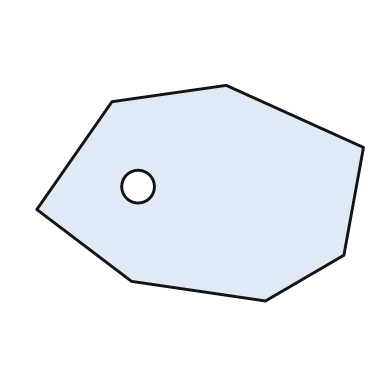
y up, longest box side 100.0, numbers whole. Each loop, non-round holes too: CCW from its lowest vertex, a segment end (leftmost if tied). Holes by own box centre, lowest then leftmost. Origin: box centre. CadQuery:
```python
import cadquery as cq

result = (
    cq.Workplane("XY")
    .moveTo(20.0, -33.0)
    .lineTo(44.0, -19.0)
    .lineTo(50.0, 14.0)
    .lineTo(8.0, 33.0)
    .lineTo(-27.0, 28.0)
    .lineTo(-50.0, -5.0)
    .lineTo(-21.0, -27.0)
    .close()
    .moveTo(-19.0, 2.0)
    .circle(5.0)
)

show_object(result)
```